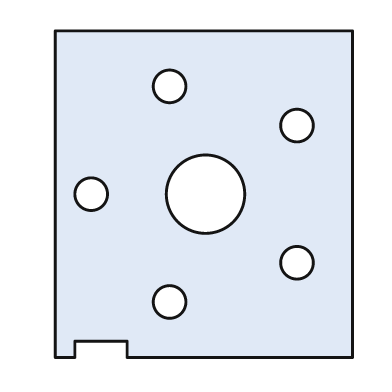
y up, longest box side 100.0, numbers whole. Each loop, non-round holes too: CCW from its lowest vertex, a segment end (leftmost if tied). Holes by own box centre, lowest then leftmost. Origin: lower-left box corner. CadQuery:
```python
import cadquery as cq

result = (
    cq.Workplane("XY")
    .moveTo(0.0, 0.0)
    .lineTo(6.0, 0.0)
    .lineTo(6.0, 5.0)
    .lineTo(22.0, 5.0)
    .lineTo(22.0, 0.0)
    .lineTo(91.0, 0.0)
    .lineTo(91.0, 100.0)
    .lineTo(0.0, 100.0)
    .close()
    .moveTo(35.0, 17.0)
    .circle(5.0)
    .moveTo(74.0, 29.0)
    .circle(5.0)
    .moveTo(11.0, 50.0)
    .circle(5.0)
    .moveTo(46.0, 50.0)
    .circle(12.0)
    .moveTo(74.0, 71.0)
    .circle(5.0)
    .moveTo(35.0, 83.0)
    .circle(5.0)
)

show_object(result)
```